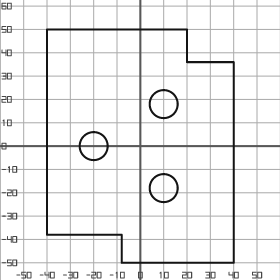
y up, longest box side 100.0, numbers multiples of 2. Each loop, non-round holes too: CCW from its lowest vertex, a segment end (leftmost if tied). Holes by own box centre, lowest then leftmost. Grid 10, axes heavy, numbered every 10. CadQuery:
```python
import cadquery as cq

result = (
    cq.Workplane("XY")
    .moveTo(-8.0, -50.0)
    .lineTo(40.0, -50.0)
    .lineTo(40.0, 36.0)
    .lineTo(20.0, 36.0)
    .lineTo(20.0, 50.0)
    .lineTo(-40.0, 50.0)
    .lineTo(-40.0, -38.0)
    .lineTo(-8.0, -38.0)
    .close()
    .moveTo(10.0, -18.0)
    .circle(6.0)
    .moveTo(-20.0, 0.0)
    .circle(6.0)
    .moveTo(10.0, 18.0)
    .circle(6.0)
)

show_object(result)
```